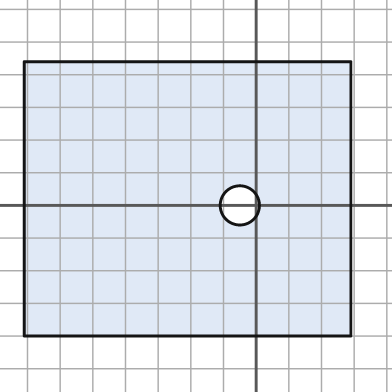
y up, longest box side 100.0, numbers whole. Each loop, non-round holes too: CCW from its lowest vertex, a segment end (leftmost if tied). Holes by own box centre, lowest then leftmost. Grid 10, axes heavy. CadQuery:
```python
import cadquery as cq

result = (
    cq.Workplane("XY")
    .moveTo(-71.0, -40.0)
    .lineTo(29.0, -40.0)
    .lineTo(29.0, 44.0)
    .lineTo(-71.0, 44.0)
    .close()
    .moveTo(-5.0, 0.0)
    .circle(6.0)
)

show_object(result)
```